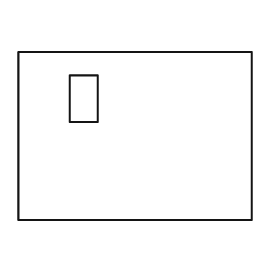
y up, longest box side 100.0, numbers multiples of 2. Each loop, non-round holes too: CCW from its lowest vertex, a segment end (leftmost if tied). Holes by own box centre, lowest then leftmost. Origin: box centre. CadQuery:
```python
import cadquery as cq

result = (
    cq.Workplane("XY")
    .moveTo(-50.0, -36.0)
    .lineTo(50.0, -36.0)
    .lineTo(50.0, 36.0)
    .lineTo(-50.0, 36.0)
    .close()
    .moveTo(-28.0, 6.0)
    .lineTo(-16.0, 6.0)
    .lineTo(-16.0, 26.0)
    .lineTo(-28.0, 26.0)
    .close()
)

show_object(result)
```